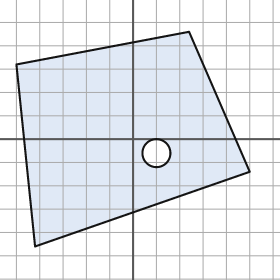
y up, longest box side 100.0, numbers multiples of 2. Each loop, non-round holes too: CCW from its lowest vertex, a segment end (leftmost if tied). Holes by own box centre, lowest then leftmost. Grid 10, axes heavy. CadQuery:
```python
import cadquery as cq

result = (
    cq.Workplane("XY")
    .moveTo(-42.0, -46.0)
    .lineTo(50.0, -14.0)
    .lineTo(24.0, 46.0)
    .lineTo(-50.0, 32.0)
    .close()
    .moveTo(10.0, -6.0)
    .circle(6.0)
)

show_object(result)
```